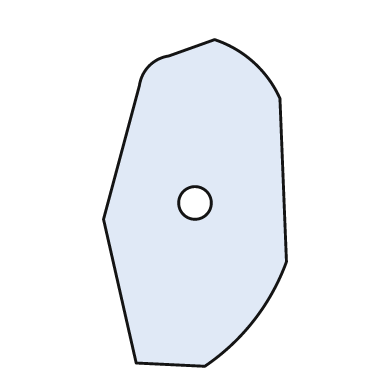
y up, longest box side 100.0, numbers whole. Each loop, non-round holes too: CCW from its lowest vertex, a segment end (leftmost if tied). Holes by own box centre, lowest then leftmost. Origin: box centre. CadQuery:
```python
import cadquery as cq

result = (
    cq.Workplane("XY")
    .moveTo(3.0, -50.0)
    .threePointArc((18.0, -36.0), (28.0, -18.0))
    .lineTo(26.0, 32.0)
    .threePointArc((18.0, 43.0), (6.0, 50.0))
    .lineTo(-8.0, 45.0)
    .threePointArc((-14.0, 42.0), (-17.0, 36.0))
    .lineTo(-28.0, -5.0)
    .lineTo(-18.0, -49.0)
    .close()
    .moveTo(0.0, 0.0)
    .circle(5.0)
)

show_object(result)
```